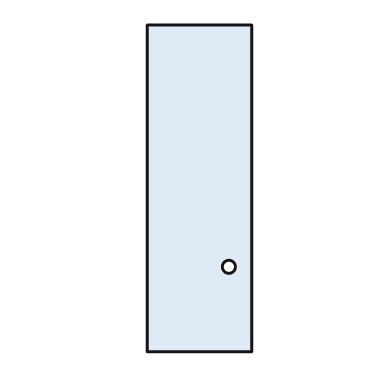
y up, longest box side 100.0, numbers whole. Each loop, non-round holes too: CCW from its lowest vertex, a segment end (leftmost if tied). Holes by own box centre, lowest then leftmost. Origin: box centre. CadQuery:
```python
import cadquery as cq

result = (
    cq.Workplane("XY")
    .moveTo(-16.0, -50.0)
    .lineTo(16.0, -50.0)
    .lineTo(16.0, 50.0)
    .lineTo(-16.0, 50.0)
    .close()
    .moveTo(9.0, -24.0)
    .circle(2.0)
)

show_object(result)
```